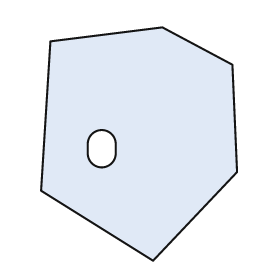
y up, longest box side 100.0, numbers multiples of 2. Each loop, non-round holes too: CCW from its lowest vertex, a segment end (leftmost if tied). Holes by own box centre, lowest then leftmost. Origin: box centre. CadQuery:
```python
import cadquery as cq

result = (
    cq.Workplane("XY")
    .moveTo(6.0, -50.0)
    .lineTo(42.0, -12.0)
    .lineTo(40.0, 34.0)
    .lineTo(10.0, 50.0)
    .lineTo(-38.0, 44.0)
    .lineTo(-42.0, -20.0)
    .close()
    .moveTo(-22.0, -4.0)
    .threePointArc((-16.0, -10.0), (-10.0, -4.0))
    .lineTo(-10.0, 0.0)
    .threePointArc((-16.0, 6.0), (-22.0, 0.0))
    .close()
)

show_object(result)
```